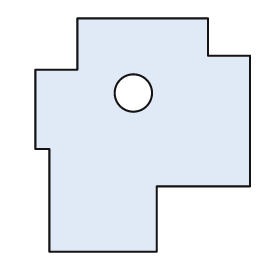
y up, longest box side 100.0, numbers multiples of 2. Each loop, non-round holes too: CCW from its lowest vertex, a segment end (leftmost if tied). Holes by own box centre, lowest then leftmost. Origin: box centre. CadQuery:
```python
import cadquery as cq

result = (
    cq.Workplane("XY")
    .moveTo(-40.0, -50.0)
    .lineTo(6.0, -50.0)
    .lineTo(6.0, -22.0)
    .lineTo(46.0, -22.0)
    .lineTo(46.0, 34.0)
    .lineTo(28.0, 34.0)
    .lineTo(28.0, 50.0)
    .lineTo(-28.0, 50.0)
    .lineTo(-28.0, 28.0)
    .lineTo(-46.0, 28.0)
    .lineTo(-46.0, -6.0)
    .lineTo(-40.0, -6.0)
    .close()
    .moveTo(-4.0, 18.0)
    .circle(8.0)
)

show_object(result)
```